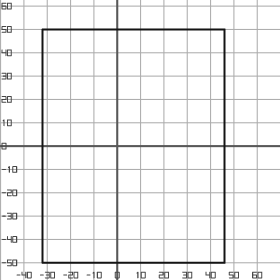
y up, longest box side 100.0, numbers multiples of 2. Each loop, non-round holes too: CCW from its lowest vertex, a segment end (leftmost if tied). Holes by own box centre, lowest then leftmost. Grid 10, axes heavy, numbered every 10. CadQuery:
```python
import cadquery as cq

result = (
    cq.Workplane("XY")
    .moveTo(-32.0, -50.0)
    .lineTo(46.0, -50.0)
    .lineTo(46.0, 50.0)
    .lineTo(-32.0, 50.0)
    .close()
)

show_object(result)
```